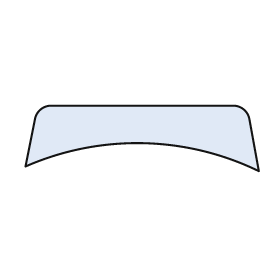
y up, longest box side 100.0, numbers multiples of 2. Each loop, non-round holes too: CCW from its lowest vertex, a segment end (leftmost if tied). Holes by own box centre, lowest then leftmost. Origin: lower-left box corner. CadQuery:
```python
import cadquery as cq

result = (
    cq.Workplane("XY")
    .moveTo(100.0, 0.0)
    .lineTo(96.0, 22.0)
    .threePointArc((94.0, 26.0), (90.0, 28.0))
    .lineTo(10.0, 28.0)
    .threePointArc((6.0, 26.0), (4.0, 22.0))
    .lineTo(0.0, 2.0)
    .threePointArc((50.0, 12.0), (100.0, 0.0))
    .close()
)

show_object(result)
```